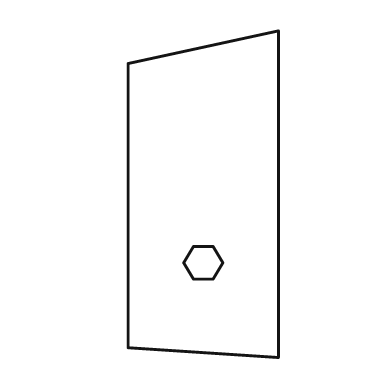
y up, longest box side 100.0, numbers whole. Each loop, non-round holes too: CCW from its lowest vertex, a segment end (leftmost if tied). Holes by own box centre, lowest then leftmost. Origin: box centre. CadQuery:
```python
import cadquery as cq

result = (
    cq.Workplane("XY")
    .moveTo(23.0, -50.0)
    .lineTo(23.0, 50.0)
    .lineTo(-23.0, 40.0)
    .lineTo(-23.0, -47.0)
    .close()
    .moveTo(-3.0, -26.0)
    .lineTo(3.0, -26.0)
    .lineTo(6.0, -21.0)
    .lineTo(3.0, -16.0)
    .lineTo(-3.0, -16.0)
    .lineTo(-6.0, -21.0)
    .close()
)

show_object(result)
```